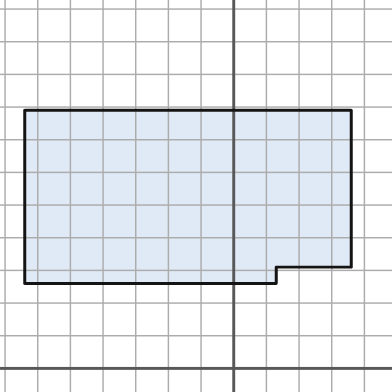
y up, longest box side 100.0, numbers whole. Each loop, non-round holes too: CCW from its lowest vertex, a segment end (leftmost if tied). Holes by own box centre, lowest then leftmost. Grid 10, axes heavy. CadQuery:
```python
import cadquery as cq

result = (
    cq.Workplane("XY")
    .moveTo(-64.0, 26.0)
    .lineTo(13.0, 26.0)
    .lineTo(13.0, 31.0)
    .lineTo(36.0, 31.0)
    .lineTo(36.0, 79.0)
    .lineTo(-64.0, 79.0)
    .close()
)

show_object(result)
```